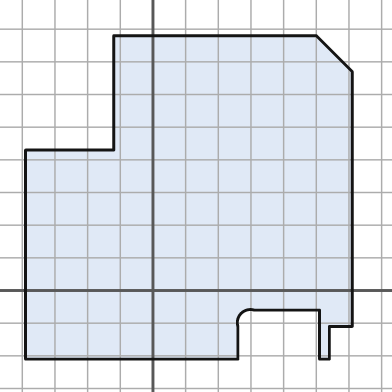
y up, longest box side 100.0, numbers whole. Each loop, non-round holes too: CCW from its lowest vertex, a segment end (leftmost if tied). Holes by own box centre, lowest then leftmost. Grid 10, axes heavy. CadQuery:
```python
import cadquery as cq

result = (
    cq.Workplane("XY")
    .moveTo(-39.0, -21.0)
    .lineTo(26.0, -21.0)
    .lineTo(26.0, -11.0)
    .threePointArc((27.0, -7.0), (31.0, -6.0))
    .lineTo(51.0, -6.0)
    .lineTo(51.0, -21.0)
    .lineTo(54.0, -21.0)
    .lineTo(54.0, -11.0)
    .lineTo(61.0, -11.0)
    .lineTo(61.0, 67.0)
    .lineTo(50.0, 78.0)
    .lineTo(-12.0, 78.0)
    .lineTo(-12.0, 43.0)
    .lineTo(-39.0, 43.0)
    .close()
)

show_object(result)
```